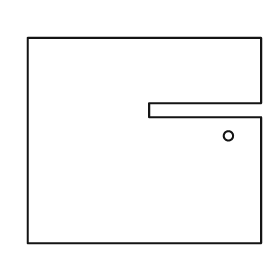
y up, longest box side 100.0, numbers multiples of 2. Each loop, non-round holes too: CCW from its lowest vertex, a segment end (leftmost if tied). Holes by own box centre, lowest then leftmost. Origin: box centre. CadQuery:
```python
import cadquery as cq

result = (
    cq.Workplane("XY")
    .moveTo(-50.0, -44.0)
    .lineTo(50.0, -44.0)
    .lineTo(50.0, 10.0)
    .lineTo(2.0, 10.0)
    .lineTo(2.0, 16.0)
    .lineTo(50.0, 16.0)
    .lineTo(50.0, 44.0)
    .lineTo(-50.0, 44.0)
    .close()
    .moveTo(36.0, 2.0)
    .circle(2.0)
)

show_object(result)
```